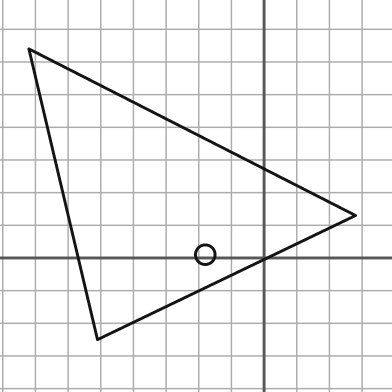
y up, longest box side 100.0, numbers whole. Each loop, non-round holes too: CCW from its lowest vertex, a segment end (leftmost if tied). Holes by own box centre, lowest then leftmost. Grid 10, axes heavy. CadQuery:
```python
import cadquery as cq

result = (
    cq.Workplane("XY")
    .moveTo(-51.0, -25.0)
    .lineTo(28.0, 13.0)
    .lineTo(-72.0, 64.0)
    .close()
    .moveTo(-18.0, 1.0)
    .circle(3.0)
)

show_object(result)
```